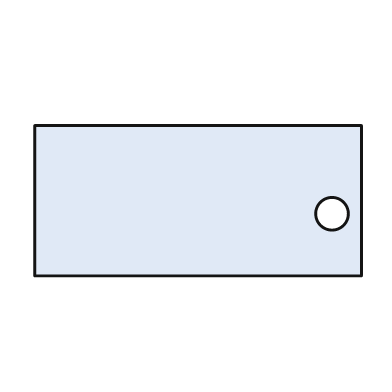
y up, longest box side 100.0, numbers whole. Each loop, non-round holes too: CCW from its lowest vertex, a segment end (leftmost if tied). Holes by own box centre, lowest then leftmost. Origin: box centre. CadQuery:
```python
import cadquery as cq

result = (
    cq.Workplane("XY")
    .moveTo(-50.0, -23.0)
    .lineTo(50.0, -23.0)
    .lineTo(50.0, 23.0)
    .lineTo(-50.0, 23.0)
    .close()
    .moveTo(41.0, -4.0)
    .circle(5.0)
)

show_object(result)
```